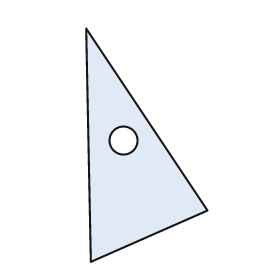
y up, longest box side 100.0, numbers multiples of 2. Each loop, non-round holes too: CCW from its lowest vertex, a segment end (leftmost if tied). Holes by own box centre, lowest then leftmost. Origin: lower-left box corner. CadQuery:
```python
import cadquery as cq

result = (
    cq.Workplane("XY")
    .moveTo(2.0, 0.0)
    .lineTo(52.0, 22.0)
    .lineTo(0.0, 100.0)
    .close()
    .moveTo(16.0, 52.0)
    .circle(6.0)
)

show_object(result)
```